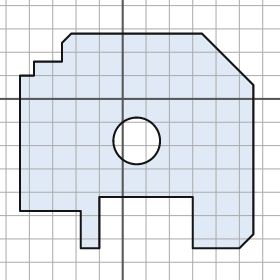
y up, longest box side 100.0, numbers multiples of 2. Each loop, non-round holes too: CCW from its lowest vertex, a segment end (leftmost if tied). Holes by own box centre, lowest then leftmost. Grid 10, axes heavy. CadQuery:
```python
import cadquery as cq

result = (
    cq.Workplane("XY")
    .moveTo(-18.0, -64.0)
    .lineTo(-10.0, -64.0)
    .lineTo(-10.0, -42.0)
    .lineTo(30.0, -42.0)
    .lineTo(30.0, -64.0)
    .lineTo(50.0, -64.0)
    .lineTo(56.0, -58.0)
    .lineTo(56.0, 6.0)
    .lineTo(34.0, 28.0)
    .lineTo(-22.0, 28.0)
    .lineTo(-26.0, 24.0)
    .lineTo(-26.0, 16.0)
    .lineTo(-38.0, 16.0)
    .lineTo(-38.0, 10.0)
    .lineTo(-44.0, 10.0)
    .lineTo(-44.0, -48.0)
    .lineTo(-18.0, -48.0)
    .close()
    .moveTo(6.0, -18.0)
    .circle(10.0)
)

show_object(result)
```